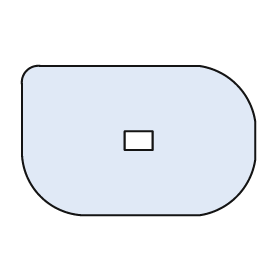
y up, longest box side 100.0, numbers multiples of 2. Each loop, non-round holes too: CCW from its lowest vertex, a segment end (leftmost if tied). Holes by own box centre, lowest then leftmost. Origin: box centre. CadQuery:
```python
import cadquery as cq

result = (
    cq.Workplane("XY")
    .moveTo(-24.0, -32.0)
    .lineTo(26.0, -32.0)
    .threePointArc((42.0, -24.0), (50.0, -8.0))
    .lineTo(50.0, 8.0)
    .threePointArc((42.0, 24.0), (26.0, 32.0))
    .lineTo(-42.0, 32.0)
    .threePointArc((-48.0, 30.0), (-50.0, 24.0))
    .lineTo(-50.0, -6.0)
    .threePointArc((-42.0, -24.0), (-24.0, -32.0))
    .close()
    .moveTo(-6.0, -4.0)
    .lineTo(6.0, -4.0)
    .lineTo(6.0, 4.0)
    .lineTo(-6.0, 4.0)
    .close()
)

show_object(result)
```